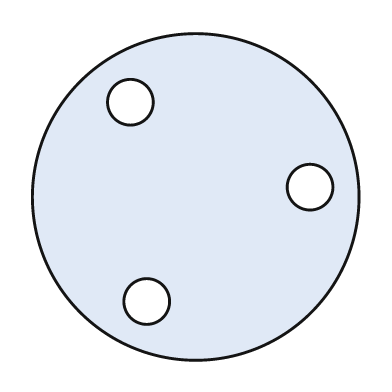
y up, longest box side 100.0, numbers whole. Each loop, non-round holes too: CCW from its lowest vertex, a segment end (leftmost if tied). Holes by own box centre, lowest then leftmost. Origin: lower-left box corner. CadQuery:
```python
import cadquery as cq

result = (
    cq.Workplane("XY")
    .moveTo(50.0, 50.0)
    .circle(50.0)
    .moveTo(35.0, 18.0)
    .circle(7.0)
    .moveTo(85.0, 53.0)
    .circle(7.0)
    .moveTo(30.0, 79.0)
    .circle(7.0)
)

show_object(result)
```